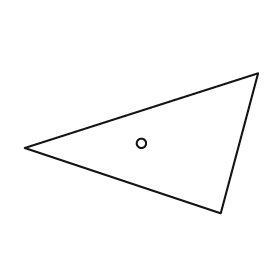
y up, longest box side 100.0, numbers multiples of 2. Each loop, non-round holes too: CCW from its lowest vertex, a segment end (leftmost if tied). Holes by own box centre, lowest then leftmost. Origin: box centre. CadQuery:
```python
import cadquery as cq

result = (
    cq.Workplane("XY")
    .moveTo(34.0, -30.0)
    .lineTo(50.0, 30.0)
    .lineTo(-50.0, -2.0)
    .close()
    .moveTo(0.0, 0.0)
    .circle(2.0)
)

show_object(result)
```